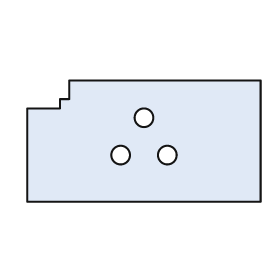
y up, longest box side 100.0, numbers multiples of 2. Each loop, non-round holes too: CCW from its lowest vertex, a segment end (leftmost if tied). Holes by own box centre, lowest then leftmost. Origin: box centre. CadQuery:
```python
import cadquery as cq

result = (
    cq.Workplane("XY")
    .moveTo(-50.0, -26.0)
    .lineTo(50.0, -26.0)
    .lineTo(50.0, 26.0)
    .lineTo(-32.0, 26.0)
    .lineTo(-32.0, 18.0)
    .lineTo(-36.0, 18.0)
    .lineTo(-36.0, 14.0)
    .lineTo(-50.0, 14.0)
    .close()
    .moveTo(-10.0, -6.0)
    .circle(4.0)
    .moveTo(10.0, -6.0)
    .circle(4.0)
    .moveTo(0.0, 10.0)
    .circle(4.0)
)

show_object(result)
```